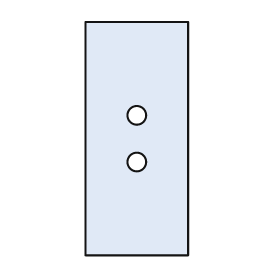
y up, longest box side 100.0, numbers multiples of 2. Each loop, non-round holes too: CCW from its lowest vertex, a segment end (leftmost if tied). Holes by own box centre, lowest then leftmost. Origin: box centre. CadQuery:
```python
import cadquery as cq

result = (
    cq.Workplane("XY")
    .moveTo(-22.0, -50.0)
    .lineTo(22.0, -50.0)
    .lineTo(22.0, 50.0)
    .lineTo(-22.0, 50.0)
    .close()
    .moveTo(0.0, -10.0)
    .circle(4.0)
    .moveTo(0.0, 10.0)
    .circle(4.0)
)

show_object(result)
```